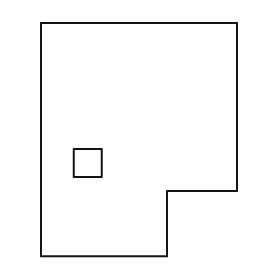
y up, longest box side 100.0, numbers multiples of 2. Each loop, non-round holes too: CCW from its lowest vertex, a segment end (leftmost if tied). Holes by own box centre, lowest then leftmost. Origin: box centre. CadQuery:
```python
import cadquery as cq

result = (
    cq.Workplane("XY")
    .moveTo(-42.0, -50.0)
    .lineTo(12.0, -50.0)
    .lineTo(12.0, -22.0)
    .lineTo(42.0, -22.0)
    .lineTo(42.0, 50.0)
    .lineTo(-42.0, 50.0)
    .close()
    .moveTo(-28.0, -16.0)
    .lineTo(-16.0, -16.0)
    .lineTo(-16.0, -4.0)
    .lineTo(-28.0, -4.0)
    .close()
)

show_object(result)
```